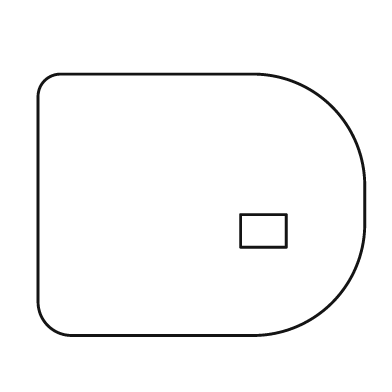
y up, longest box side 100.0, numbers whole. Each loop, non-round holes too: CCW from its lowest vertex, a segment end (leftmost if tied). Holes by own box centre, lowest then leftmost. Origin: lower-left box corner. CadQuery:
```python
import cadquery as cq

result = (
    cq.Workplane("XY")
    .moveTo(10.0, 0.0)
    .lineTo(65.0, 0.0)
    .threePointArc((90.0, 10.0), (100.0, 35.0))
    .lineTo(100.0, 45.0)
    .threePointArc((90.0, 70.0), (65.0, 80.0))
    .lineTo(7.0, 80.0)
    .threePointArc((2.0, 78.0), (0.0, 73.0))
    .lineTo(0.0, 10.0)
    .threePointArc((3.0, 3.0), (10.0, 0.0))
    .close()
    .moveTo(62.0, 27.0)
    .lineTo(76.0, 27.0)
    .lineTo(76.0, 37.0)
    .lineTo(62.0, 37.0)
    .close()
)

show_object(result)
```